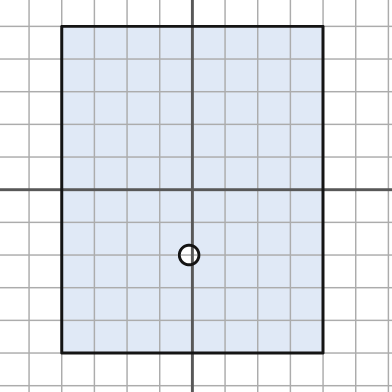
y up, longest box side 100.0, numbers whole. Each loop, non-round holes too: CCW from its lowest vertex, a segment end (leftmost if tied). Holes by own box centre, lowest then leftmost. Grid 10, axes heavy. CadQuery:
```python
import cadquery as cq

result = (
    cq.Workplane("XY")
    .moveTo(-40.0, -50.0)
    .lineTo(40.0, -50.0)
    .lineTo(40.0, 50.0)
    .lineTo(-40.0, 50.0)
    .close()
    .moveTo(-1.0, -20.0)
    .circle(3.0)
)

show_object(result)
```